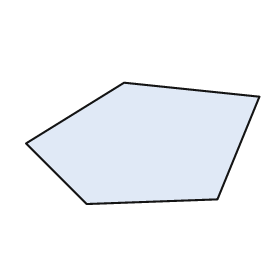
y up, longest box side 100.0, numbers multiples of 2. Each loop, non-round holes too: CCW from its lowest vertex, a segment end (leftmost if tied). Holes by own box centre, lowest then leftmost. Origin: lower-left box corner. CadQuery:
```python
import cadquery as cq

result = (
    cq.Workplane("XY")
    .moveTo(26.0, 0.0)
    .lineTo(82.0, 2.0)
    .lineTo(100.0, 46.0)
    .lineTo(42.0, 52.0)
    .lineTo(0.0, 26.0)
    .close()
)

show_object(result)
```